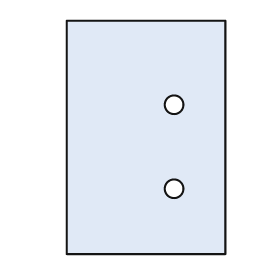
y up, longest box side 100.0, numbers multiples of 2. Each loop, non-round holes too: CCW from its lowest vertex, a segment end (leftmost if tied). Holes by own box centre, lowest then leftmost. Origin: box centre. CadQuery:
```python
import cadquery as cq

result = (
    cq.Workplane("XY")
    .moveTo(-34.0, -50.0)
    .lineTo(34.0, -50.0)
    .lineTo(34.0, 50.0)
    .lineTo(-34.0, 50.0)
    .close()
    .moveTo(12.0, -22.0)
    .circle(4.0)
    .moveTo(12.0, 14.0)
    .circle(4.0)
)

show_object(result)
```